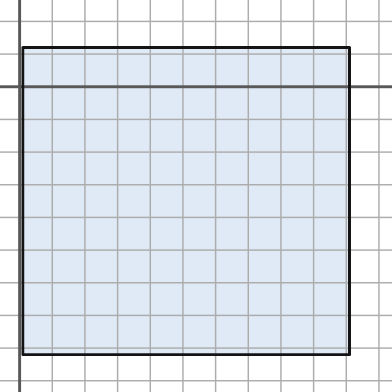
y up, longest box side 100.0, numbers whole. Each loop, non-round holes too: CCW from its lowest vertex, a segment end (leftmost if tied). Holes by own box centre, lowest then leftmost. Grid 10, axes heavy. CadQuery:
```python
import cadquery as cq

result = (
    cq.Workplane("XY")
    .moveTo(1.0, -82.0)
    .lineTo(101.0, -82.0)
    .lineTo(101.0, 12.0)
    .lineTo(1.0, 12.0)
    .close()
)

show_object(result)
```